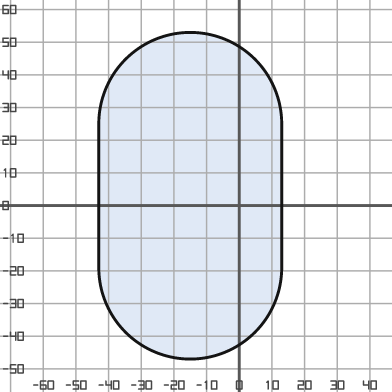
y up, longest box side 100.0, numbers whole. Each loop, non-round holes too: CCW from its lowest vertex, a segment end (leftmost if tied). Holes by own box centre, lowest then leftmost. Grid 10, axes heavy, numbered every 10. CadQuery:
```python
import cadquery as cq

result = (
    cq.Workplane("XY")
    .moveTo(-43.0, -19.0)
    .threePointArc((-15.0, -47.0), (13.0, -19.0))
    .lineTo(13.0, 25.0)
    .threePointArc((-15.0, 53.0), (-43.0, 25.0))
    .close()
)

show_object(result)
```